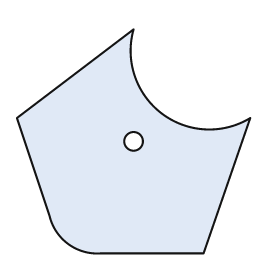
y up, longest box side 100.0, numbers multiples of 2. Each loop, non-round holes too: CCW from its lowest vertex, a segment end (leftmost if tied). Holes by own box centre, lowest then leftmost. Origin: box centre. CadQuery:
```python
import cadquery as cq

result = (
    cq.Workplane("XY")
    .moveTo(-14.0, -48.0)
    .lineTo(30.0, -48.0)
    .lineTo(50.0, 10.0)
    .threePointArc((12.0, 12.0), (0.0, 48.0))
    .lineTo(-50.0, 10.0)
    .lineTo(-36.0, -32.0)
    .threePointArc((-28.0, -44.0), (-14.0, -48.0))
    .close()
    .moveTo(0.0, 0.0)
    .circle(4.0)
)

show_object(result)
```